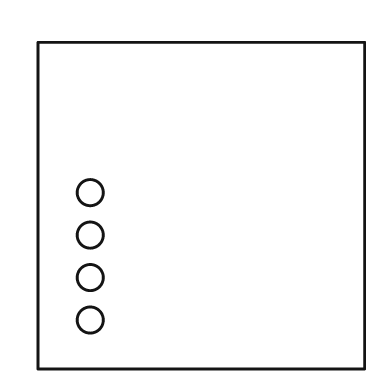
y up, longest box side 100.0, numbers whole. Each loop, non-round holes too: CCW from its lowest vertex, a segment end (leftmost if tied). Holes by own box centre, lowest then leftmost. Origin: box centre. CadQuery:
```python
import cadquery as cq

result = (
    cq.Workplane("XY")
    .moveTo(-50.0, -50.0)
    .lineTo(50.0, -50.0)
    .lineTo(50.0, 50.0)
    .lineTo(-50.0, 50.0)
    .close()
    .moveTo(-34.0, -35.0)
    .circle(4.0)
    .moveTo(-34.0, -22.0)
    .circle(4.0)
    .moveTo(-34.0, -9.0)
    .circle(4.0)
    .moveTo(-34.0, 4.0)
    .circle(4.0)
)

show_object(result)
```